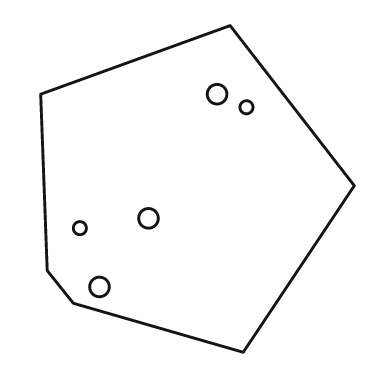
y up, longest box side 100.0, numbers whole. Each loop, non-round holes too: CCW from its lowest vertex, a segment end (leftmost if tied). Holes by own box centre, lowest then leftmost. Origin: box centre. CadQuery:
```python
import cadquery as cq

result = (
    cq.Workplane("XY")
    .moveTo(14.0, -50.0)
    .lineTo(48.0, 1.0)
    .lineTo(10.0, 50.0)
    .lineTo(-48.0, 29.0)
    .lineTo(-46.0, -25.0)
    .lineTo(-38.0, -35.0)
    .close()
    .moveTo(-30.0, -30.0)
    .circle(3.0)
    .moveTo(-36.0, -12.0)
    .circle(2.0)
    .moveTo(-15.0, -9.0)
    .circle(3.0)
    .moveTo(15.0, 25.0)
    .circle(2.0)
    .moveTo(6.0, 29.0)
    .circle(3.0)
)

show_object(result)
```